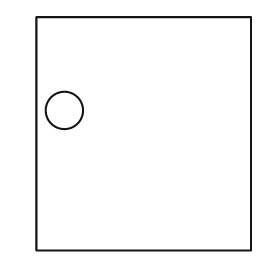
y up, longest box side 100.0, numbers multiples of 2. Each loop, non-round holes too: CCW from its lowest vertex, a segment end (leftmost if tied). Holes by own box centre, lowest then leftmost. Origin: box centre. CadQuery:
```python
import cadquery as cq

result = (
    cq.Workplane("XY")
    .moveTo(-46.0, -50.0)
    .lineTo(46.0, -50.0)
    .lineTo(46.0, 50.0)
    .lineTo(-46.0, 50.0)
    .close()
    .moveTo(-34.0, 10.0)
    .circle(8.0)
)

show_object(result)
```